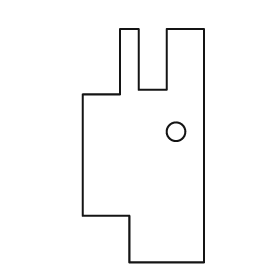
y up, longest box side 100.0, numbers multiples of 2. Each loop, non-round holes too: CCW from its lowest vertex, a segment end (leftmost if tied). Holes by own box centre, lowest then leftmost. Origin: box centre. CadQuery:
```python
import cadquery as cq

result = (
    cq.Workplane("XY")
    .moveTo(-6.0, -50.0)
    .lineTo(26.0, -50.0)
    .lineTo(26.0, 50.0)
    .lineTo(10.0, 50.0)
    .lineTo(10.0, 24.0)
    .lineTo(-2.0, 24.0)
    .lineTo(-2.0, 50.0)
    .lineTo(-10.0, 50.0)
    .lineTo(-10.0, 22.0)
    .lineTo(-26.0, 22.0)
    .lineTo(-26.0, -30.0)
    .lineTo(-6.0, -30.0)
    .close()
    .moveTo(14.0, 6.0)
    .circle(4.0)
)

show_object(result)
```